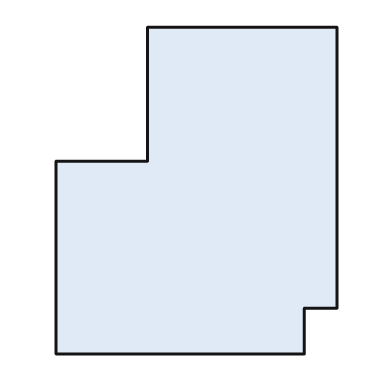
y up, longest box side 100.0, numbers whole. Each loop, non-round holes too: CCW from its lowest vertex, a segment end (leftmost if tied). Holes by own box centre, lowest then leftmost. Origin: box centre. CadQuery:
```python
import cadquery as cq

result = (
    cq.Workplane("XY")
    .moveTo(-43.0, -50.0)
    .lineTo(33.0, -50.0)
    .lineTo(33.0, -36.0)
    .lineTo(43.0, -36.0)
    .lineTo(43.0, 50.0)
    .lineTo(-15.0, 50.0)
    .lineTo(-15.0, 9.0)
    .lineTo(-43.0, 9.0)
    .close()
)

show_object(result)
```